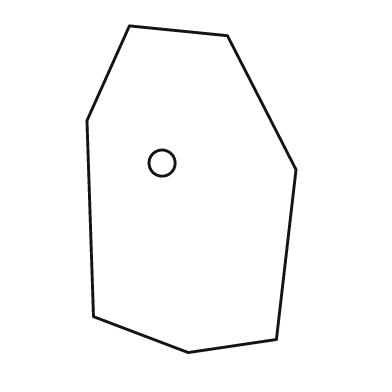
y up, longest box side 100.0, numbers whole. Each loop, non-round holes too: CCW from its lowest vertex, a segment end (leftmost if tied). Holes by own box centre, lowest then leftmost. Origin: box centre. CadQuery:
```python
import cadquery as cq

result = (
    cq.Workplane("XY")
    .moveTo(-1.0, -50.0)
    .lineTo(26.0, -46.0)
    .lineTo(32.0, 6.0)
    .lineTo(11.0, 47.0)
    .lineTo(-19.0, 50.0)
    .lineTo(-32.0, 21.0)
    .lineTo(-30.0, -39.0)
    .close()
    .moveTo(-9.0, 8.0)
    .circle(4.0)
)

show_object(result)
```